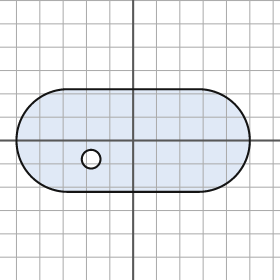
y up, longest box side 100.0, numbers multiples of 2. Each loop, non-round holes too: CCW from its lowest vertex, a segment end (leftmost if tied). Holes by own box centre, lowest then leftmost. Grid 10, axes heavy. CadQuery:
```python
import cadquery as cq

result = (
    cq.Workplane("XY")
    .moveTo(-28.0, -22.0)
    .lineTo(28.0, -22.0)
    .threePointArc((50.0, 0.0), (28.0, 22.0))
    .lineTo(-28.0, 22.0)
    .threePointArc((-50.0, 0.0), (-28.0, -22.0))
    .close()
    .moveTo(-18.0, -8.0)
    .circle(4.0)
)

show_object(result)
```